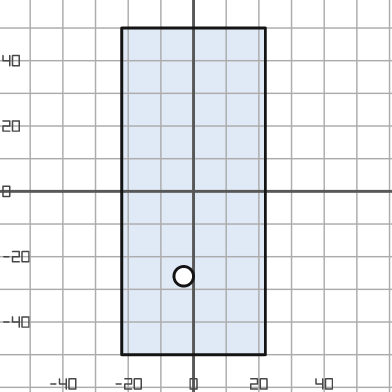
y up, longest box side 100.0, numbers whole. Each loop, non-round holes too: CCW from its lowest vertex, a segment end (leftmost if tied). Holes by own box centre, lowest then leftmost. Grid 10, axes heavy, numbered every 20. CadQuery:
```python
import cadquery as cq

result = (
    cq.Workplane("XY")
    .moveTo(-22.0, -50.0)
    .lineTo(22.0, -50.0)
    .lineTo(22.0, 50.0)
    .lineTo(-22.0, 50.0)
    .close()
    .moveTo(-3.0, -26.0)
    .circle(3.0)
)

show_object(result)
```